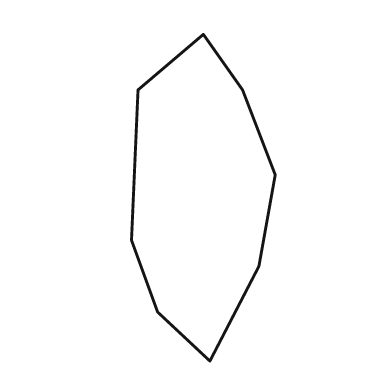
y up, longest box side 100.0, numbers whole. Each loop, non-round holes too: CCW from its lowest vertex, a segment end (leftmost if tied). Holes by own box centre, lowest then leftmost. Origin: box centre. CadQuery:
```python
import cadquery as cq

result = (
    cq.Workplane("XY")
    .moveTo(2.0, -50.0)
    .lineTo(17.0, -21.0)
    .lineTo(22.0, 7.0)
    .lineTo(12.0, 33.0)
    .lineTo(0.0, 50.0)
    .lineTo(-20.0, 33.0)
    .lineTo(-22.0, -13.0)
    .lineTo(-14.0, -35.0)
    .close()
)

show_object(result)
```